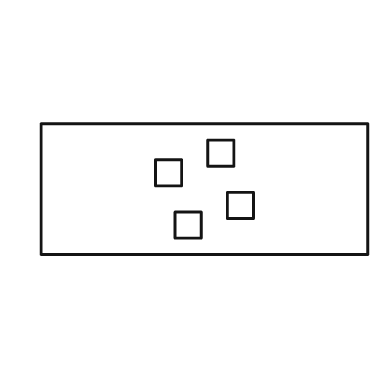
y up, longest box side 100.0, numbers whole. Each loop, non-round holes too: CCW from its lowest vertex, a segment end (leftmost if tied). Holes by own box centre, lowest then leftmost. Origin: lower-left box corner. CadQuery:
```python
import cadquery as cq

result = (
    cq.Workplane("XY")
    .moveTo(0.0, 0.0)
    .lineTo(100.0, 0.0)
    .lineTo(100.0, 40.0)
    .lineTo(0.0, 40.0)
    .close()
    .moveTo(41.0, 5.0)
    .lineTo(49.0, 5.0)
    .lineTo(49.0, 13.0)
    .lineTo(41.0, 13.0)
    .close()
    .moveTo(57.0, 11.0)
    .lineTo(65.0, 11.0)
    .lineTo(65.0, 19.0)
    .lineTo(57.0, 19.0)
    .close()
    .moveTo(35.0, 21.0)
    .lineTo(43.0, 21.0)
    .lineTo(43.0, 29.0)
    .lineTo(35.0, 29.0)
    .close()
    .moveTo(51.0, 27.0)
    .lineTo(59.0, 27.0)
    .lineTo(59.0, 35.0)
    .lineTo(51.0, 35.0)
    .close()
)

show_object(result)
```